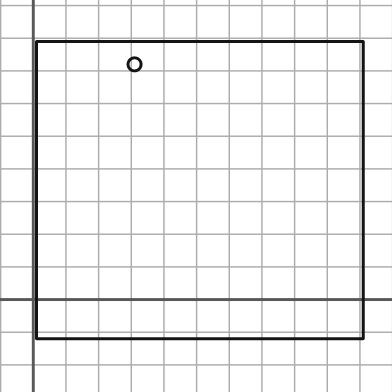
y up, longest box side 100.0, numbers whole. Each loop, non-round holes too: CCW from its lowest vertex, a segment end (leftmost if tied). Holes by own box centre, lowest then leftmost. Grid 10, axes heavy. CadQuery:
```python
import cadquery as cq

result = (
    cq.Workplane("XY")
    .moveTo(1.0, -12.0)
    .lineTo(101.0, -12.0)
    .lineTo(101.0, 79.0)
    .lineTo(1.0, 79.0)
    .close()
    .moveTo(31.0, 72.0)
    .circle(2.0)
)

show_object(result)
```